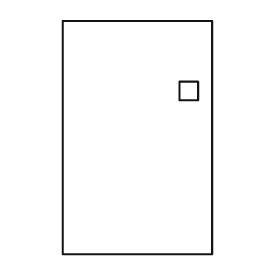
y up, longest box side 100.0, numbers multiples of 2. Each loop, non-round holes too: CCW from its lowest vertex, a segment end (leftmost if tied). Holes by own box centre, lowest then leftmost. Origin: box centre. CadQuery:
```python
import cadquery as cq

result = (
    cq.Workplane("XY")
    .moveTo(-32.0, -50.0)
    .lineTo(32.0, -50.0)
    .lineTo(32.0, 50.0)
    .lineTo(-32.0, 50.0)
    .close()
    .moveTo(18.0, 16.0)
    .lineTo(26.0, 16.0)
    .lineTo(26.0, 24.0)
    .lineTo(18.0, 24.0)
    .close()
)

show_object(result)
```